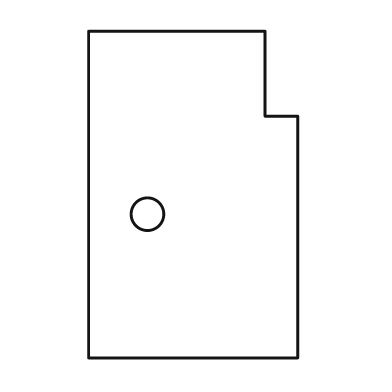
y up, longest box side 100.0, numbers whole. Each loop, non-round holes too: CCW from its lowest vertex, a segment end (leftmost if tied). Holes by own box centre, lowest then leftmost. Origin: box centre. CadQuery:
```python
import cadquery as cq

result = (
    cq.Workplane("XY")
    .moveTo(-32.0, -50.0)
    .lineTo(32.0, -50.0)
    .lineTo(32.0, 24.0)
    .lineTo(22.0, 24.0)
    .lineTo(22.0, 50.0)
    .lineTo(-32.0, 50.0)
    .close()
    .moveTo(-14.0, -6.0)
    .circle(5.0)
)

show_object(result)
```